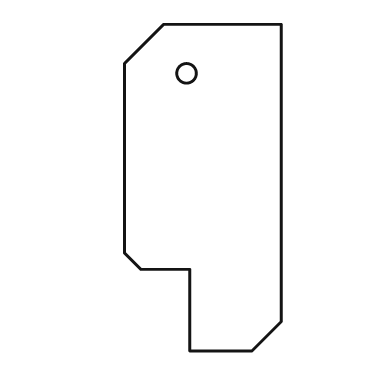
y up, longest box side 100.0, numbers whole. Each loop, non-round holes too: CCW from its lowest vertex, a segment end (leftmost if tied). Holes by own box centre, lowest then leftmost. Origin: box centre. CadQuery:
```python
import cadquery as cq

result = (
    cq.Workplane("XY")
    .moveTo(-4.0, -50.0)
    .lineTo(15.0, -50.0)
    .lineTo(24.0, -41.0)
    .lineTo(24.0, 50.0)
    .lineTo(-12.0, 50.0)
    .lineTo(-24.0, 38.0)
    .lineTo(-24.0, -20.0)
    .lineTo(-19.0, -25.0)
    .lineTo(-4.0, -25.0)
    .close()
    .moveTo(-5.0, 35.0)
    .circle(3.0)
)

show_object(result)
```